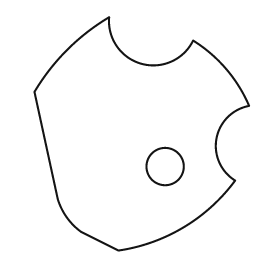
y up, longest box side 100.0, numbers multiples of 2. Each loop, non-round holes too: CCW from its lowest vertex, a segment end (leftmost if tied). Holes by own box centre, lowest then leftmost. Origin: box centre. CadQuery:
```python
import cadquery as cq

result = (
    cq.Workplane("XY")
    .moveTo(-10.0, -50.0)
    .threePointArc((18.0, -40.0), (40.0, -20.0))
    .threePointArc((32.0, -2.0), (46.0, 12.0))
    .threePointArc((36.0, 28.0), (22.0, 40.0))
    .threePointArc((0.0, 30.0), (-14.0, 50.0))
    .threePointArc((-32.0, 36.0), (-46.0, 18.0))
    .lineTo(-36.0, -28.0)
    .threePointArc((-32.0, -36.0), (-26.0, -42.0))
    .close()
    .moveTo(10.0, -14.0)
    .circle(8.0)
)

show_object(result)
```